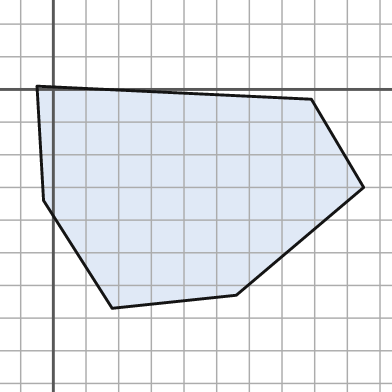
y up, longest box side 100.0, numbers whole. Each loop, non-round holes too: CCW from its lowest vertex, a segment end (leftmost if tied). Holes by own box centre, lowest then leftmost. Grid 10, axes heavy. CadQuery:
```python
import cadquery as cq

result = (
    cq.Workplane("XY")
    .moveTo(18.0, -67.0)
    .lineTo(56.0, -63.0)
    .lineTo(95.0, -30.0)
    .lineTo(79.0, -3.0)
    .lineTo(-5.0, 1.0)
    .lineTo(-3.0, -34.0)
    .close()
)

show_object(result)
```